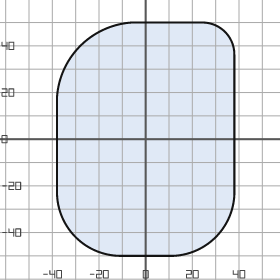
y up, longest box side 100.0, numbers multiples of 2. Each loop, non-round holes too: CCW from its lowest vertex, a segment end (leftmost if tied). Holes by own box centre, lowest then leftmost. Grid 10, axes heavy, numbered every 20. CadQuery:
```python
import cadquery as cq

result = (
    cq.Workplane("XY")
    .moveTo(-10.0, -50.0)
    .lineTo(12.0, -50.0)
    .threePointArc((30.0, -42.0), (38.0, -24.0))
    .lineTo(38.0, 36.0)
    .threePointArc((34.0, 46.0), (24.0, 50.0))
    .lineTo(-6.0, 50.0)
    .threePointArc((-28.0, 40.0), (-38.0, 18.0))
    .lineTo(-38.0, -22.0)
    .threePointArc((-30.0, -42.0), (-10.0, -50.0))
    .close()
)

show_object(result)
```